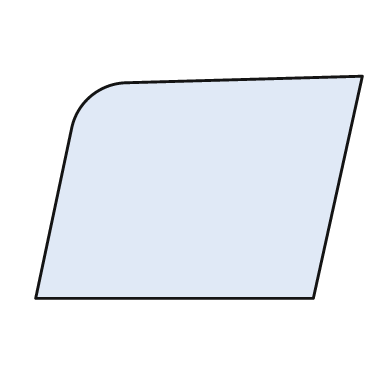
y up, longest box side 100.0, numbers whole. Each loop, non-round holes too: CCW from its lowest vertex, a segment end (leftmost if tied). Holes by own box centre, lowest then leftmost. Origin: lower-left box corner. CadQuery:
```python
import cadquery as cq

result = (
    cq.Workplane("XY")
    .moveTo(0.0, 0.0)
    .lineTo(85.0, 0.0)
    .lineTo(100.0, 68.0)
    .lineTo(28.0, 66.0)
    .threePointArc((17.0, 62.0), (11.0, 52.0))
    .close()
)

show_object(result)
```